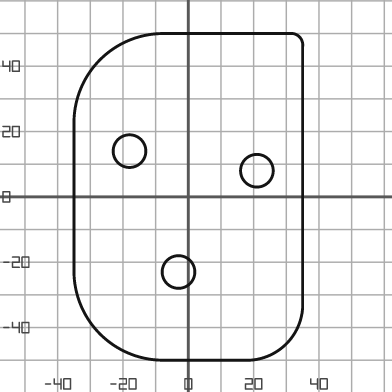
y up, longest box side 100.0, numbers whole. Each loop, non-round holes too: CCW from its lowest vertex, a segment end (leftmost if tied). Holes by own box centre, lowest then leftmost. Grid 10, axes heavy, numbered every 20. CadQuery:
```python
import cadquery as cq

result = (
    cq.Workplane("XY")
    .moveTo(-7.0, -50.0)
    .lineTo(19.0, -50.0)
    .threePointArc((30.0, -45.0), (35.0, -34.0))
    .lineTo(35.0, 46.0)
    .threePointArc((34.0, 49.0), (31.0, 50.0))
    .lineTo(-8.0, 50.0)
    .threePointArc((-27.0, 42.0), (-35.0, 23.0))
    .lineTo(-35.0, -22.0)
    .threePointArc((-27.0, -42.0), (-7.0, -50.0))
    .close()
    .moveTo(-3.0, -23.0)
    .circle(5.0)
    .moveTo(21.0, 8.0)
    .circle(5.0)
    .moveTo(-18.0, 14.0)
    .circle(5.0)
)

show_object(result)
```